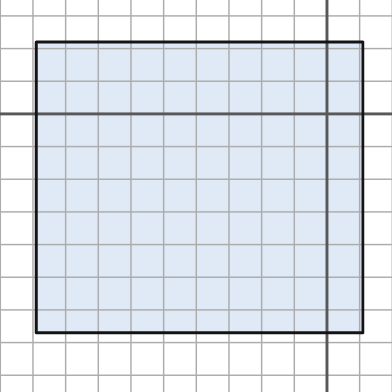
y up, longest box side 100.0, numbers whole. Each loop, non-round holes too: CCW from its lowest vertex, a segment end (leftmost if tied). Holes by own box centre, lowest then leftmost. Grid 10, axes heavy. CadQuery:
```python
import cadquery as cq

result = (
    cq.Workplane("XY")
    .moveTo(-89.0, -67.0)
    .lineTo(11.0, -67.0)
    .lineTo(11.0, 22.0)
    .lineTo(-89.0, 22.0)
    .close()
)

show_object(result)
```